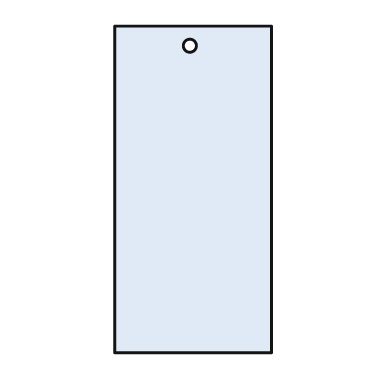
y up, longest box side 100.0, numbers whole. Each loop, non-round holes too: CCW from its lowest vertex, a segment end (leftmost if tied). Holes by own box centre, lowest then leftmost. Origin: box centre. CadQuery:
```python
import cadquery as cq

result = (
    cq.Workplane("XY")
    .moveTo(-24.0, -50.0)
    .lineTo(24.0, -50.0)
    .lineTo(24.0, 50.0)
    .lineTo(-24.0, 50.0)
    .close()
    .moveTo(-1.0, 44.0)
    .circle(2.0)
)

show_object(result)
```